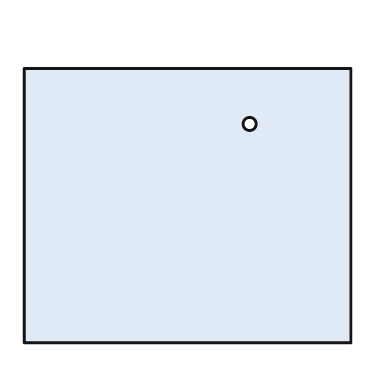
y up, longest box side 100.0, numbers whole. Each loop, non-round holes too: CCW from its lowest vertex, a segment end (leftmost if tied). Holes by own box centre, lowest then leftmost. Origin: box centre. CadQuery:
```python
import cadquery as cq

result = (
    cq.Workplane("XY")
    .moveTo(-50.0, -42.0)
    .lineTo(50.0, -42.0)
    .lineTo(50.0, 42.0)
    .lineTo(-50.0, 42.0)
    .close()
    .moveTo(19.0, 25.0)
    .circle(2.0)
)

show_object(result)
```